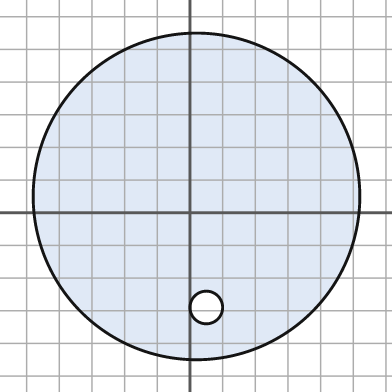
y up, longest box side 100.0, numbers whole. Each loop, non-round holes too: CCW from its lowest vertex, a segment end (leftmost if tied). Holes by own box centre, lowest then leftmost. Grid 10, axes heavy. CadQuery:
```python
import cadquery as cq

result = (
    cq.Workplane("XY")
    .moveTo(2.0, 5.0)
    .circle(50.0)
    .moveTo(5.0, -29.0)
    .circle(5.0)
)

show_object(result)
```